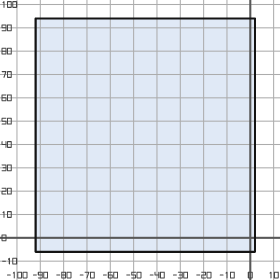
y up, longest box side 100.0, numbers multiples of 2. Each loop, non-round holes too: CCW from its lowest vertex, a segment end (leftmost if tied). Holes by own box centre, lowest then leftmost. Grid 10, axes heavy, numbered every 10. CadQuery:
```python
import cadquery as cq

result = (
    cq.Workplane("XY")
    .moveTo(-92.0, -6.0)
    .lineTo(2.0, -6.0)
    .lineTo(2.0, 94.0)
    .lineTo(-92.0, 94.0)
    .close()
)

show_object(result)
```